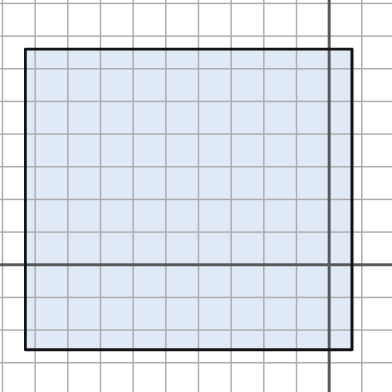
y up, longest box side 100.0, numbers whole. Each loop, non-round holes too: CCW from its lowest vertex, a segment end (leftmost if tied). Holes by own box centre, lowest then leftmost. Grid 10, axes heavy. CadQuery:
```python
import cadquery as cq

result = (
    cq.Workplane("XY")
    .moveTo(-93.0, -26.0)
    .lineTo(7.0, -26.0)
    .lineTo(7.0, 66.0)
    .lineTo(-93.0, 66.0)
    .close()
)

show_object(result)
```